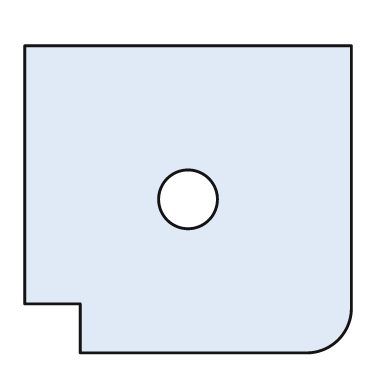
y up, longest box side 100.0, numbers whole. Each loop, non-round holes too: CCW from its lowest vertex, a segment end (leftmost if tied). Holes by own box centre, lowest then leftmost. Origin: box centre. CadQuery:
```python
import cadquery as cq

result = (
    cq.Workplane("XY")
    .moveTo(-33.0, -47.0)
    .lineTo(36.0, -47.0)
    .threePointArc((46.0, -43.0), (50.0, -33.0))
    .lineTo(50.0, 47.0)
    .lineTo(-50.0, 47.0)
    .lineTo(-50.0, -32.0)
    .lineTo(-33.0, -32.0)
    .close()
    .moveTo(0.0, 0.0)
    .circle(9.0)
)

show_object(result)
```